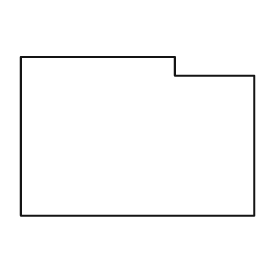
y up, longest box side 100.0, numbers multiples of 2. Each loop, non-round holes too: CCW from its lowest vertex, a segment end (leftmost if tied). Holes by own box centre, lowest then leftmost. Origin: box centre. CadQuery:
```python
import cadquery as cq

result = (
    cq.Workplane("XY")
    .moveTo(-50.0, -34.0)
    .lineTo(50.0, -34.0)
    .lineTo(50.0, 26.0)
    .lineTo(16.0, 26.0)
    .lineTo(16.0, 34.0)
    .lineTo(-50.0, 34.0)
    .close()
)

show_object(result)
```